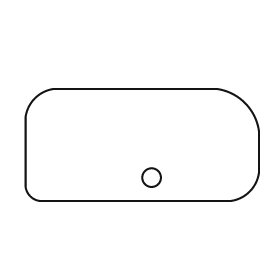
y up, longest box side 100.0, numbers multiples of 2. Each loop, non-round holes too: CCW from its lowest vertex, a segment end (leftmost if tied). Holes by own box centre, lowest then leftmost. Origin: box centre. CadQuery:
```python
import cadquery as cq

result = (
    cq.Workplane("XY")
    .moveTo(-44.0, -24.0)
    .lineTo(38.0, -24.0)
    .threePointArc((46.0, -20.0), (50.0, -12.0))
    .lineTo(50.0, 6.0)
    .threePointArc((44.0, 18.0), (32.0, 24.0))
    .lineTo(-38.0, 24.0)
    .threePointArc((-46.0, 20.0), (-50.0, 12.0))
    .lineTo(-50.0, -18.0)
    .threePointArc((-48.0, -22.0), (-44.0, -24.0))
    .close()
    .moveTo(4.0, -14.0)
    .circle(4.0)
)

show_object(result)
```